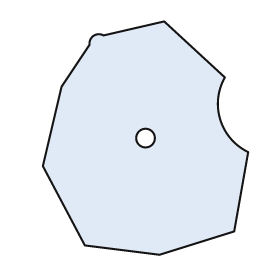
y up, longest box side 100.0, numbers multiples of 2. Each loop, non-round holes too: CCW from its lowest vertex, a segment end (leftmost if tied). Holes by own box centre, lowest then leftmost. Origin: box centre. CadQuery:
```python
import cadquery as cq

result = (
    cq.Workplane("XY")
    .moveTo(6.0, -50.0)
    .lineTo(38.0, -40.0)
    .lineTo(44.0, -6.0)
    .threePointArc((32.0, 8.0), (34.0, 26.0))
    .lineTo(8.0, 50.0)
    .lineTo(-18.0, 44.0)
    .threePointArc((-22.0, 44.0), (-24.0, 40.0))
    .lineTo(-36.0, 22.0)
    .lineTo(-44.0, -12.0)
    .lineTo(-26.0, -46.0)
    .close()
    .moveTo(0.0, 0.0)
    .circle(4.0)
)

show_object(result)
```